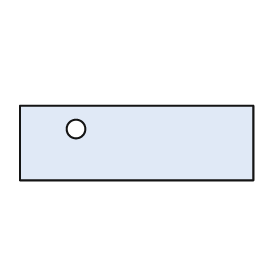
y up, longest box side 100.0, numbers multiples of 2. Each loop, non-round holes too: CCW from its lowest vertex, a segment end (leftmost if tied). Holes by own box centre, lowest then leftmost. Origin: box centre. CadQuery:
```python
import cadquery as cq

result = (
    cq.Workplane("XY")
    .moveTo(-50.0, -16.0)
    .lineTo(50.0, -16.0)
    .lineTo(50.0, 16.0)
    .lineTo(-50.0, 16.0)
    .close()
    .moveTo(-26.0, 6.0)
    .circle(4.0)
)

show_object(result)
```